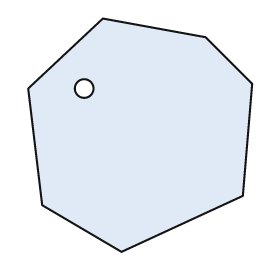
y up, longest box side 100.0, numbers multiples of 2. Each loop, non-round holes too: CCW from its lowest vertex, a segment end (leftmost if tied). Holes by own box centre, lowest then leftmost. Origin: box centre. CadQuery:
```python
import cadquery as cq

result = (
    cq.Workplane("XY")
    .moveTo(-8.0, -50.0)
    .lineTo(44.0, -26.0)
    .lineTo(48.0, 22.0)
    .lineTo(28.0, 42.0)
    .lineTo(-16.0, 50.0)
    .lineTo(-48.0, 20.0)
    .lineTo(-42.0, -30.0)
    .close()
    .moveTo(-24.0, 20.0)
    .circle(4.0)
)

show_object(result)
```